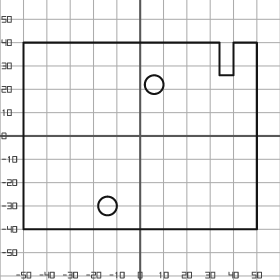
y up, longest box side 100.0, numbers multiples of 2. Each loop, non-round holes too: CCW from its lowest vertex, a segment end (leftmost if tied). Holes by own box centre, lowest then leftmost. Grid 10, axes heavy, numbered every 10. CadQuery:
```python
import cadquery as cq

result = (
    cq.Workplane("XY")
    .moveTo(-50.0, -40.0)
    .lineTo(50.0, -40.0)
    .lineTo(50.0, 40.0)
    .lineTo(40.0, 40.0)
    .lineTo(40.0, 26.0)
    .lineTo(34.0, 26.0)
    .lineTo(34.0, 40.0)
    .lineTo(-50.0, 40.0)
    .close()
    .moveTo(-14.0, -30.0)
    .circle(4.0)
    .moveTo(6.0, 22.0)
    .circle(4.0)
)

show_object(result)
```